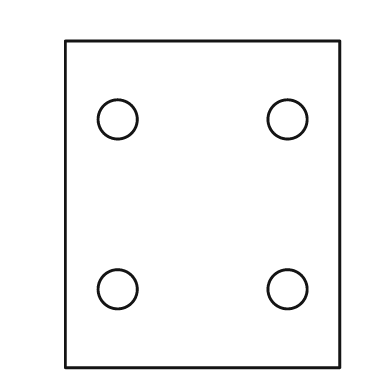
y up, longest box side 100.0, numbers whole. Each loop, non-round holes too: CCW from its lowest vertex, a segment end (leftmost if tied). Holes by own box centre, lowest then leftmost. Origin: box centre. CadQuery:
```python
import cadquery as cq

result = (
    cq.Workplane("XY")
    .moveTo(-42.0, -50.0)
    .lineTo(42.0, -50.0)
    .lineTo(42.0, 50.0)
    .lineTo(-42.0, 50.0)
    .close()
    .moveTo(-26.0, -26.0)
    .circle(6.0)
    .moveTo(26.0, -26.0)
    .circle(6.0)
    .moveTo(-26.0, 26.0)
    .circle(6.0)
    .moveTo(26.0, 26.0)
    .circle(6.0)
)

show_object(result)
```